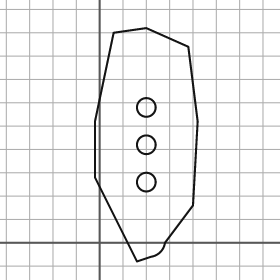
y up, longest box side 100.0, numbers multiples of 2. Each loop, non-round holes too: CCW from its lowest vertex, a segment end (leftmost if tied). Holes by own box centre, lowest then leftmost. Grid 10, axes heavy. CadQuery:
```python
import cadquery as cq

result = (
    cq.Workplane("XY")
    .moveTo(16.0, -8.0)
    .lineTo(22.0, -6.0)
    .threePointArc((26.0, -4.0), (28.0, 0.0))
    .lineTo(40.0, 16.0)
    .lineTo(42.0, 52.0)
    .lineTo(38.0, 84.0)
    .lineTo(20.0, 92.0)
    .lineTo(6.0, 90.0)
    .lineTo(-2.0, 52.0)
    .lineTo(-2.0, 28.0)
    .close()
    .moveTo(20.0, 26.0)
    .circle(4.0)
    .moveTo(20.0, 42.0)
    .circle(4.0)
    .moveTo(20.0, 58.0)
    .circle(4.0)
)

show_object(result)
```